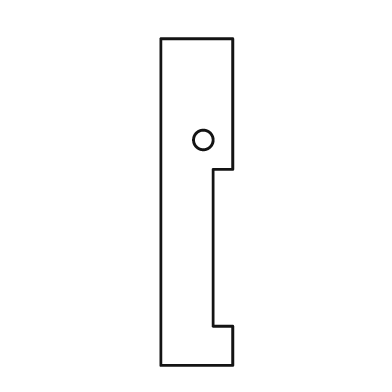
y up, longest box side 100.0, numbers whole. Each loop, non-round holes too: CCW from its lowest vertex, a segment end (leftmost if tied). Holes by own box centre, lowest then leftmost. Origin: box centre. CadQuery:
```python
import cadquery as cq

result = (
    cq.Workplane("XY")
    .moveTo(-11.0, -50.0)
    .lineTo(11.0, -50.0)
    .lineTo(11.0, -38.0)
    .lineTo(5.0, -38.0)
    .lineTo(5.0, 10.0)
    .lineTo(11.0, 10.0)
    .lineTo(11.0, 50.0)
    .lineTo(-11.0, 50.0)
    .close()
    .moveTo(2.0, 19.0)
    .circle(3.0)
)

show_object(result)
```